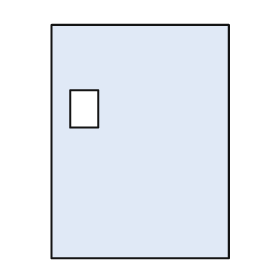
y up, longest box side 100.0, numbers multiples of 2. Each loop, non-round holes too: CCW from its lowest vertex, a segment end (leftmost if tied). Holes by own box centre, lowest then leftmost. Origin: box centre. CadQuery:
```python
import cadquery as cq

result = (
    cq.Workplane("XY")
    .moveTo(-38.0, -50.0)
    .lineTo(38.0, -50.0)
    .lineTo(38.0, 50.0)
    .lineTo(-38.0, 50.0)
    .close()
    .moveTo(-30.0, 6.0)
    .lineTo(-18.0, 6.0)
    .lineTo(-18.0, 22.0)
    .lineTo(-30.0, 22.0)
    .close()
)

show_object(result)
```